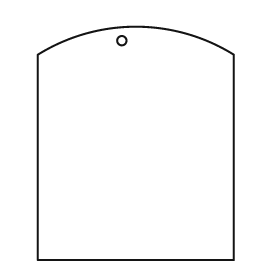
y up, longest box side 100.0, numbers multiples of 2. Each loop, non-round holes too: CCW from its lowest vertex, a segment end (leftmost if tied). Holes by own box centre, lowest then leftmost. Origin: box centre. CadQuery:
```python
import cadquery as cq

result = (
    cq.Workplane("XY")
    .moveTo(-42.0, -50.0)
    .lineTo(42.0, -50.0)
    .lineTo(42.0, 38.0)
    .threePointArc((0.0, 50.0), (-42.0, 38.0))
    .close()
    .moveTo(-6.0, 44.0)
    .circle(2.0)
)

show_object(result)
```